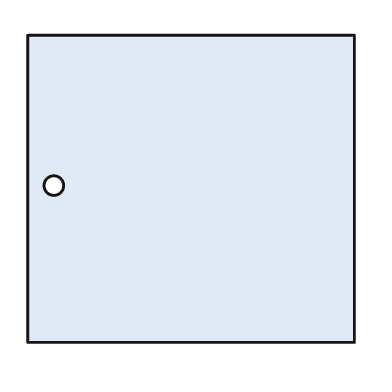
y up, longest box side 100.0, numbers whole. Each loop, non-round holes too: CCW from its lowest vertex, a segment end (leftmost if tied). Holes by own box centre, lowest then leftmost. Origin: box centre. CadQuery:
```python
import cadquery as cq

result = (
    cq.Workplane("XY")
    .moveTo(-50.0, -47.0)
    .lineTo(50.0, -47.0)
    .lineTo(50.0, 47.0)
    .lineTo(-50.0, 47.0)
    .close()
    .moveTo(-42.0, 1.0)
    .circle(3.0)
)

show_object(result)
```